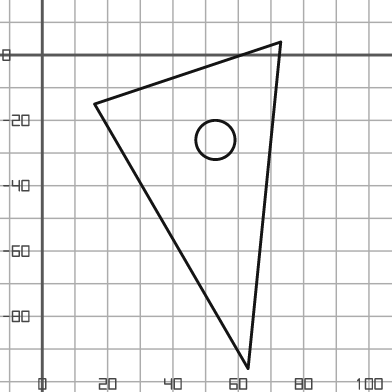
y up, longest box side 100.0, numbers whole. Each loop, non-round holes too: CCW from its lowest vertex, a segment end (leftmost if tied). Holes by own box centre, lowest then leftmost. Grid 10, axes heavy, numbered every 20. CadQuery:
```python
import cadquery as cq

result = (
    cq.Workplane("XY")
    .moveTo(63.0, -96.0)
    .lineTo(73.0, 4.0)
    .lineTo(16.0, -15.0)
    .close()
    .moveTo(53.0, -26.0)
    .circle(6.0)
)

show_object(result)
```